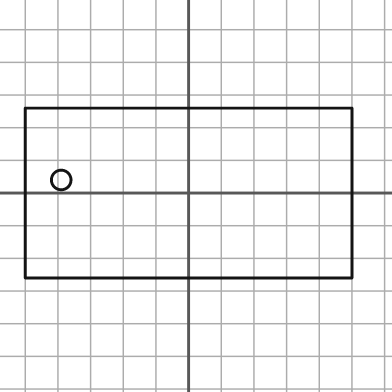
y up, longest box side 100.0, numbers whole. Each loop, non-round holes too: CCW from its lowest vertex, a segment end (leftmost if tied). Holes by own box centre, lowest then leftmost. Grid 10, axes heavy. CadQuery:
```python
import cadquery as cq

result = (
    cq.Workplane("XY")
    .moveTo(-50.0, -26.0)
    .lineTo(50.0, -26.0)
    .lineTo(50.0, 26.0)
    .lineTo(-50.0, 26.0)
    .close()
    .moveTo(-39.0, 4.0)
    .circle(3.0)
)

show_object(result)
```